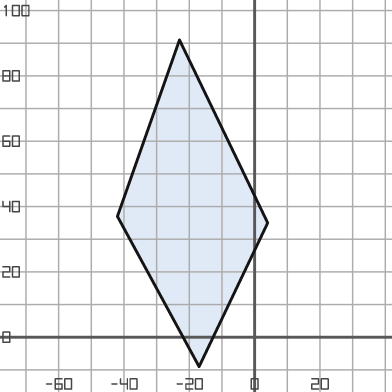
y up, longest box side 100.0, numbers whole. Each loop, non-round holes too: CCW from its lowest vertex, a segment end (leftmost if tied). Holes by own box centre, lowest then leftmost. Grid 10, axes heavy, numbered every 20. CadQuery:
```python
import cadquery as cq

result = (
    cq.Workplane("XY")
    .moveTo(-17.0, -9.0)
    .lineTo(4.0, 35.0)
    .lineTo(-23.0, 91.0)
    .lineTo(-42.0, 37.0)
    .close()
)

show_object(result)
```